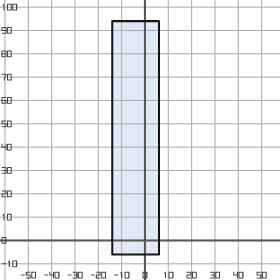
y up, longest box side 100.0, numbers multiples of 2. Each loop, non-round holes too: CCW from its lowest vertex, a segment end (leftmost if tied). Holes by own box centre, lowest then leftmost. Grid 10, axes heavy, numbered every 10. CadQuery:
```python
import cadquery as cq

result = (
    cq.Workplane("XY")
    .moveTo(-14.0, -6.0)
    .lineTo(6.0, -6.0)
    .lineTo(6.0, 94.0)
    .lineTo(-14.0, 94.0)
    .close()
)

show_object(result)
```